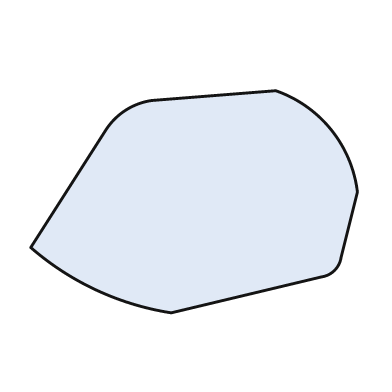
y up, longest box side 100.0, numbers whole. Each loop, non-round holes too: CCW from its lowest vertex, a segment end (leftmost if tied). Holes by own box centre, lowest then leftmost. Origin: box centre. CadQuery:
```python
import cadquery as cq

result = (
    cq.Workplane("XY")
    .moveTo(-7.0, -34.0)
    .lineTo(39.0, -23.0)
    .threePointArc((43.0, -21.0), (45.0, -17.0))
    .lineTo(50.0, 3.0)
    .threePointArc((42.0, 22.0), (25.0, 34.0))
    .lineTo(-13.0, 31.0)
    .threePointArc((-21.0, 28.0), (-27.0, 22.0))
    .lineTo(-50.0, -14.0)
    .threePointArc((-30.0, -27.0), (-7.0, -34.0))
    .close()
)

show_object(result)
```